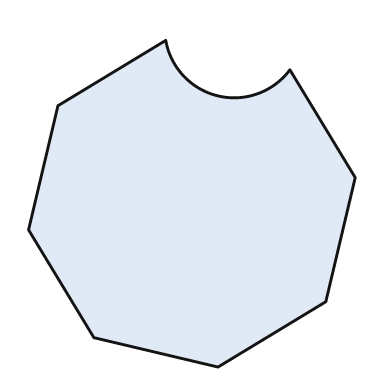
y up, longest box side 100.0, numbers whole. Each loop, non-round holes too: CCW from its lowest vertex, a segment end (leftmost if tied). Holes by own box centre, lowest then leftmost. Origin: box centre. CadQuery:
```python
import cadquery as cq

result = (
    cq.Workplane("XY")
    .moveTo(8.0, -50.0)
    .lineTo(41.0, -30.0)
    .lineTo(50.0, 8.0)
    .lineTo(30.0, 41.0)
    .threePointArc((8.0, 33.0), (-8.0, 50.0))
    .lineTo(-41.0, 30.0)
    .lineTo(-50.0, -8.0)
    .lineTo(-30.0, -41.0)
    .close()
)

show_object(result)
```